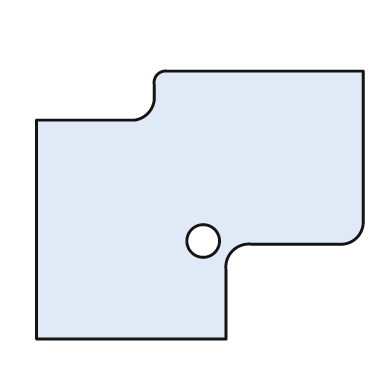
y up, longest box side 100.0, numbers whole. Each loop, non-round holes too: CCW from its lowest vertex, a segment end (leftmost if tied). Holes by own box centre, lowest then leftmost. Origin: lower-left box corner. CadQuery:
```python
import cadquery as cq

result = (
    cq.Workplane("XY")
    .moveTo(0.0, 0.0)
    .lineTo(58.0, 0.0)
    .lineTo(58.0, 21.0)
    .threePointArc((60.0, 27.0), (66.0, 29.0))
    .lineTo(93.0, 29.0)
    .threePointArc((98.0, 31.0), (100.0, 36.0))
    .lineTo(100.0, 82.0)
    .lineTo(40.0, 82.0)
    .threePointArc((37.0, 81.0), (36.0, 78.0))
    .lineTo(36.0, 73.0)
    .threePointArc((34.0, 69.0), (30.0, 67.0))
    .lineTo(0.0, 67.0)
    .close()
    .moveTo(51.0, 30.0)
    .circle(5.0)
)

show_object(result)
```